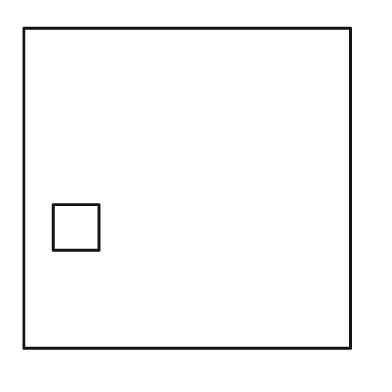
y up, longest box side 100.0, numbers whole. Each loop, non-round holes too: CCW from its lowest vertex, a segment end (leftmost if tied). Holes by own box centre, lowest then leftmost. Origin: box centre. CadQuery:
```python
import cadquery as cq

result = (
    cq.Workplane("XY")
    .moveTo(-50.0, -49.0)
    .lineTo(50.0, -49.0)
    .lineTo(50.0, 49.0)
    .lineTo(-50.0, 49.0)
    .close()
    .moveTo(-41.0, -19.0)
    .lineTo(-27.0, -19.0)
    .lineTo(-27.0, -5.0)
    .lineTo(-41.0, -5.0)
    .close()
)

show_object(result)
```